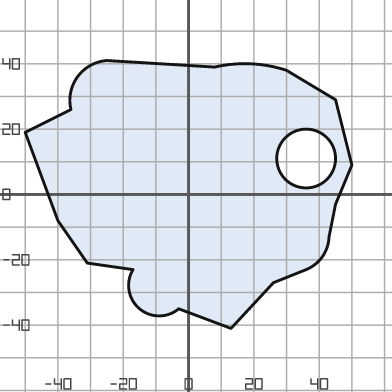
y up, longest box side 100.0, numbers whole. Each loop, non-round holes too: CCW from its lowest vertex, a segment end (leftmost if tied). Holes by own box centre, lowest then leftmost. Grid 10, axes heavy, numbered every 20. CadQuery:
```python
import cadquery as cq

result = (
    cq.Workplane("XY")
    .moveTo(13.0, -41.0)
    .lineTo(26.0, -27.0)
    .lineTo(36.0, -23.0)
    .threePointArc((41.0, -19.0), (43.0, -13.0))
    .lineTo(45.0, -3.0)
    .lineTo(50.0, 9.0)
    .lineTo(45.0, 29.0)
    .lineTo(30.0, 38.0)
    .threePointArc((19.0, 40.0), (8.0, 39.0))
    .lineTo(-25.0, 41.0)
    .threePointArc((-34.0, 36.0), (-36.0, 26.0))
    .lineTo(-50.0, 19.0)
    .lineTo(-40.0, -8.0)
    .lineTo(-31.0, -21.0)
    .lineTo(-17.0, -23.0)
    .threePointArc((-15.0, -35.0), (-3.0, -35.0))
    .close()
    .moveTo(36.0, 11.0)
    .circle(9.0)
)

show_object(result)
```